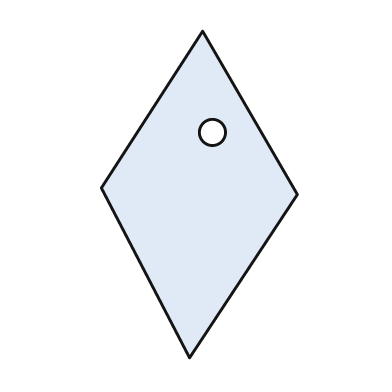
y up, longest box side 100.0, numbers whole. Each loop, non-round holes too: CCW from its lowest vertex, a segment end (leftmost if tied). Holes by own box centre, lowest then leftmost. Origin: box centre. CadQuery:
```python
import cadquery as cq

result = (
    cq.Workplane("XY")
    .moveTo(-3.0, -50.0)
    .lineTo(30.0, 0.0)
    .lineTo(1.0, 50.0)
    .lineTo(-30.0, 2.0)
    .close()
    .moveTo(4.0, 19.0)
    .circle(4.0)
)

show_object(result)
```